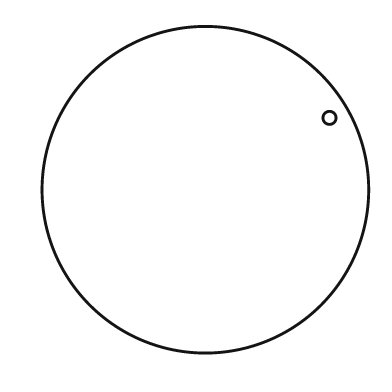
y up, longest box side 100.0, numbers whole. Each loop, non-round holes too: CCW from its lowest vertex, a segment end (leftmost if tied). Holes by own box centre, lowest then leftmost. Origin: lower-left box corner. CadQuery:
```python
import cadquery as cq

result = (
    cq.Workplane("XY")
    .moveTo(50.0, 50.0)
    .circle(50.0)
    .moveTo(88.0, 72.0)
    .circle(2.0)
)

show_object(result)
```